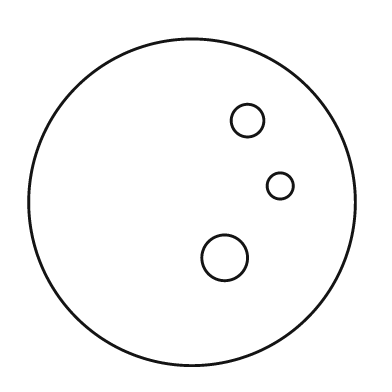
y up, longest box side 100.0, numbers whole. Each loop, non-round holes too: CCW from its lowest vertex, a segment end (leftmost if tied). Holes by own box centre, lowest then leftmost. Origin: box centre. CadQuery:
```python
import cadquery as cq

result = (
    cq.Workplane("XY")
    .moveTo(0.0, 0.0)
    .circle(50.0)
    .moveTo(10.0, -17.0)
    .circle(7.0)
    .moveTo(27.0, 5.0)
    .circle(4.0)
    .moveTo(17.0, 25.0)
    .circle(5.0)
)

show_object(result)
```